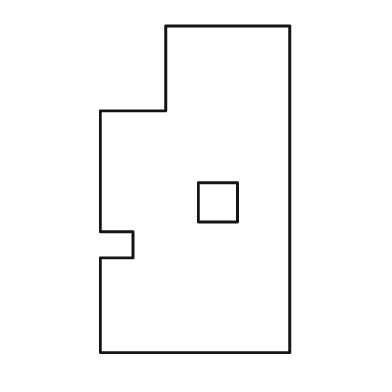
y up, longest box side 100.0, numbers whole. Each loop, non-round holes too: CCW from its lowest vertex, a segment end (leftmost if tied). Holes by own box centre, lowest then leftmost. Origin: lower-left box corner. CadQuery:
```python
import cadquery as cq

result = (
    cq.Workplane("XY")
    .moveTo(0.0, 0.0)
    .lineTo(58.0, 0.0)
    .lineTo(58.0, 100.0)
    .lineTo(20.0, 100.0)
    .lineTo(20.0, 74.0)
    .lineTo(0.0, 74.0)
    .lineTo(0.0, 37.0)
    .lineTo(10.0, 37.0)
    .lineTo(10.0, 29.0)
    .lineTo(0.0, 29.0)
    .close()
    .moveTo(30.0, 40.0)
    .lineTo(42.0, 40.0)
    .lineTo(42.0, 52.0)
    .lineTo(30.0, 52.0)
    .close()
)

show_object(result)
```